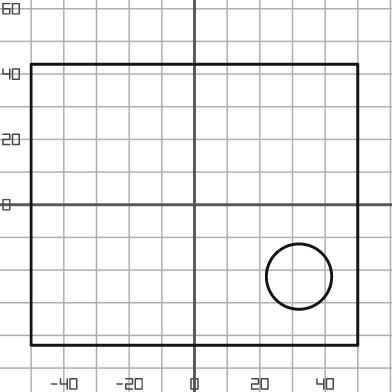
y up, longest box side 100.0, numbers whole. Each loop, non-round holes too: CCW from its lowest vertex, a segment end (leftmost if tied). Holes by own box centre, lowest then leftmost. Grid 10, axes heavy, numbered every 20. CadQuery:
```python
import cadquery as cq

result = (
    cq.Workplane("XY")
    .moveTo(-50.0, -43.0)
    .lineTo(50.0, -43.0)
    .lineTo(50.0, 43.0)
    .lineTo(-50.0, 43.0)
    .close()
    .moveTo(32.0, -22.0)
    .circle(10.0)
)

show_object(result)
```